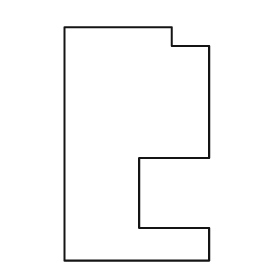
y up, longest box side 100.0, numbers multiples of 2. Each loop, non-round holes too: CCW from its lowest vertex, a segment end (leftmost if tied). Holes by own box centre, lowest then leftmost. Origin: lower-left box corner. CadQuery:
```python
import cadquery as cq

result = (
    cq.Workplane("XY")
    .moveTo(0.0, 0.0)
    .lineTo(62.0, 0.0)
    .lineTo(62.0, 14.0)
    .lineTo(32.0, 14.0)
    .lineTo(32.0, 44.0)
    .lineTo(62.0, 44.0)
    .lineTo(62.0, 92.0)
    .lineTo(46.0, 92.0)
    .lineTo(46.0, 100.0)
    .lineTo(0.0, 100.0)
    .close()
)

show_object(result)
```